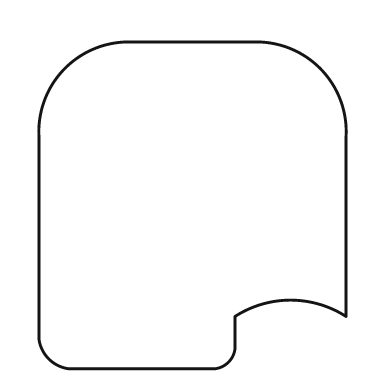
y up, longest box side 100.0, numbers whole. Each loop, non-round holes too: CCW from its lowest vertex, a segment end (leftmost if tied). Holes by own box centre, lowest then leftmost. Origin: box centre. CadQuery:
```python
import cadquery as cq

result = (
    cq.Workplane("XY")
    .moveTo(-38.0, -50.0)
    .lineTo(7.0, -50.0)
    .threePointArc((11.0, -48.0), (13.0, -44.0))
    .lineTo(13.0, -34.0)
    .threePointArc((30.0, -29.0), (47.0, -34.0))
    .lineTo(47.0, 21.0)
    .threePointArc((39.0, 42.0), (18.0, 50.0))
    .lineTo(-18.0, 50.0)
    .threePointArc((-39.0, 42.0), (-47.0, 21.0))
    .lineTo(-47.0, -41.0)
    .threePointArc((-44.0, -47.0), (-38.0, -50.0))
    .close()
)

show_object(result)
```